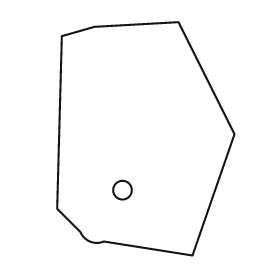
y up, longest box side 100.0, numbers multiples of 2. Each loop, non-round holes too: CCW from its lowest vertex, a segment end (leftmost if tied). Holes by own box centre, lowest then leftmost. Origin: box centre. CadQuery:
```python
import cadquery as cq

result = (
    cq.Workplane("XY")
    .moveTo(20.0, -50.0)
    .lineTo(38.0, 2.0)
    .lineTo(14.0, 50.0)
    .lineTo(-22.0, 48.0)
    .lineTo(-36.0, 44.0)
    .lineTo(-38.0, -30.0)
    .lineTo(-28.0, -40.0)
    .threePointArc((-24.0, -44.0), (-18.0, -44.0))
    .close()
    .moveTo(-10.0, -22.0)
    .circle(4.0)
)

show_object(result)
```